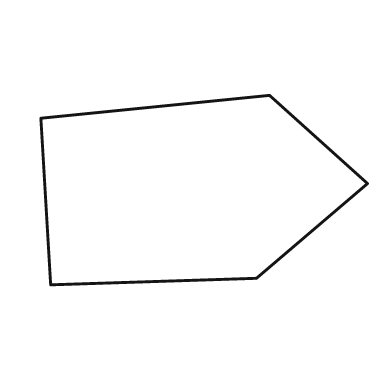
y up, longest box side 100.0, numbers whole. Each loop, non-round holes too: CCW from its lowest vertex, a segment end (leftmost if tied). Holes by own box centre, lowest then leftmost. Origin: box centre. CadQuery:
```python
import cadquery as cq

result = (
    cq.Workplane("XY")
    .moveTo(-47.0, -29.0)
    .lineTo(16.0, -27.0)
    .lineTo(50.0, 2.0)
    .lineTo(20.0, 29.0)
    .lineTo(-50.0, 22.0)
    .close()
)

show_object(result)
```